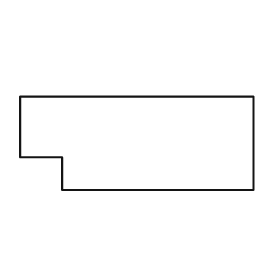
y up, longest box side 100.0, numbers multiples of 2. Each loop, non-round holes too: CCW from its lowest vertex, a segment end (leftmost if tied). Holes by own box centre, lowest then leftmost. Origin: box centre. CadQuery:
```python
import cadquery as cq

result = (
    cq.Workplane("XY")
    .moveTo(-32.0, -20.0)
    .lineTo(50.0, -20.0)
    .lineTo(50.0, 20.0)
    .lineTo(-50.0, 20.0)
    .lineTo(-50.0, -6.0)
    .lineTo(-32.0, -6.0)
    .close()
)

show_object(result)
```